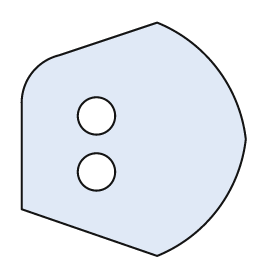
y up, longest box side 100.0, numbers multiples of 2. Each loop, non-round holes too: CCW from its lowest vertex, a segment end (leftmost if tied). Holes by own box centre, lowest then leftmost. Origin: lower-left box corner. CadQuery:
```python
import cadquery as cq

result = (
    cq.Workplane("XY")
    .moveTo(58.0, 0.0)
    .threePointArc((84.0, 20.0), (96.0, 50.0))
    .threePointArc((84.0, 80.0), (58.0, 100.0))
    .lineTo(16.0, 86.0)
    .threePointArc((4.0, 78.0), (0.0, 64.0))
    .lineTo(0.0, 20.0)
    .close()
    .moveTo(32.0, 36.0)
    .circle(8.0)
    .moveTo(32.0, 60.0)
    .circle(8.0)
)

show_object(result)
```